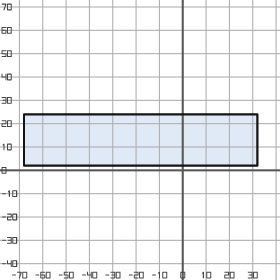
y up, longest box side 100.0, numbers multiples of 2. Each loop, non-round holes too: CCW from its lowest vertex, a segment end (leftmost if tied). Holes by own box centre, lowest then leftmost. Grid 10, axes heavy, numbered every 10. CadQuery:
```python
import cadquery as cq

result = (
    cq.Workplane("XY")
    .moveTo(-68.0, 2.0)
    .lineTo(32.0, 2.0)
    .lineTo(32.0, 24.0)
    .lineTo(-68.0, 24.0)
    .close()
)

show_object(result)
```